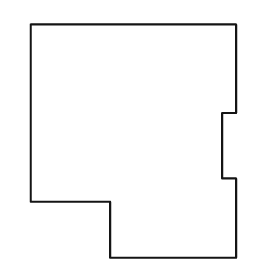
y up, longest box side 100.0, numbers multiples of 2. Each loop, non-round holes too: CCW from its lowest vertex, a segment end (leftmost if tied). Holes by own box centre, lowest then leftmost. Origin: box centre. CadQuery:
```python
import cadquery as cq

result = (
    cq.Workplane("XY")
    .moveTo(-10.0, -50.0)
    .lineTo(44.0, -50.0)
    .lineTo(44.0, -16.0)
    .lineTo(38.0, -16.0)
    .lineTo(38.0, 12.0)
    .lineTo(44.0, 12.0)
    .lineTo(44.0, 50.0)
    .lineTo(-44.0, 50.0)
    .lineTo(-44.0, -26.0)
    .lineTo(-10.0, -26.0)
    .close()
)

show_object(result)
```